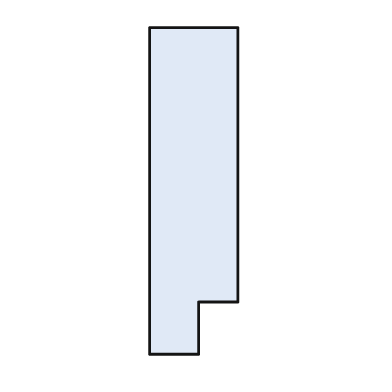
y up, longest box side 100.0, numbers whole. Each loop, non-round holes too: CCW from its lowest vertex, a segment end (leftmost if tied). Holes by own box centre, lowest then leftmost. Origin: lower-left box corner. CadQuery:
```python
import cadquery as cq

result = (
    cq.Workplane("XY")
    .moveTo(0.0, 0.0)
    .lineTo(15.0, 0.0)
    .lineTo(15.0, 16.0)
    .lineTo(27.0, 16.0)
    .lineTo(27.0, 100.0)
    .lineTo(0.0, 100.0)
    .close()
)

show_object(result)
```